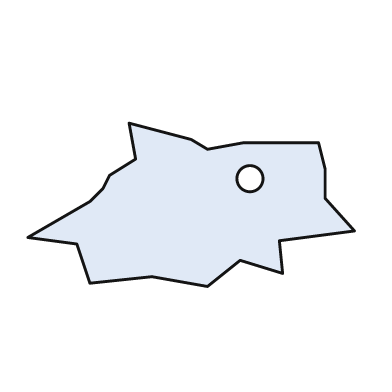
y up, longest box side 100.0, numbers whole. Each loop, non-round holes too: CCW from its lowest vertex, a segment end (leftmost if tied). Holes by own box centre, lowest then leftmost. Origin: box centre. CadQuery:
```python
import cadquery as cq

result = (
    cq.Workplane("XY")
    .moveTo(5.0, -25.0)
    .lineTo(15.0, -17.0)
    .lineTo(28.0, -21.0)
    .lineTo(27.0, -11.0)
    .lineTo(50.0, -8.0)
    .lineTo(41.0, 2.0)
    .lineTo(41.0, 11.0)
    .lineTo(39.0, 19.0)
    .lineTo(16.0, 19.0)
    .lineTo(5.0, 17.0)
    .lineTo(0.0, 20.0)
    .lineTo(-19.0, 25.0)
    .lineTo(-17.0, 14.0)
    .lineTo(-25.0, 9.0)
    .lineTo(-27.0, 5.0)
    .lineTo(-31.0, 1.0)
    .lineTo(-50.0, -10.0)
    .lineTo(-35.0, -12.0)
    .lineTo(-31.0, -24.0)
    .lineTo(-12.0, -22.0)
    .close()
    .moveTo(18.0, 8.0)
    .circle(4.0)
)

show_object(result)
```